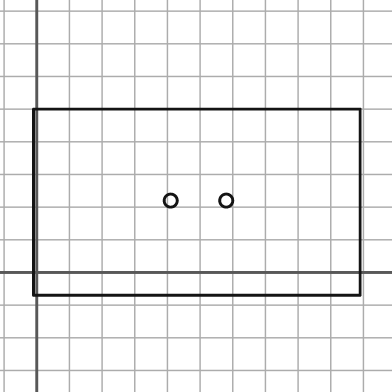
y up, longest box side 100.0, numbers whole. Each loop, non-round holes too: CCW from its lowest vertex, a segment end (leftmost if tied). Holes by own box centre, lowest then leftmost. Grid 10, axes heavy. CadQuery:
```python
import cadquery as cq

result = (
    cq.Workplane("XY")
    .moveTo(-1.0, -7.0)
    .lineTo(99.0, -7.0)
    .lineTo(99.0, 50.0)
    .lineTo(-1.0, 50.0)
    .close()
    .moveTo(41.0, 22.0)
    .circle(2.0)
    .moveTo(58.0, 22.0)
    .circle(2.0)
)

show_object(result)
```